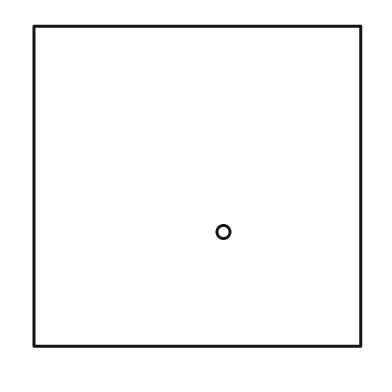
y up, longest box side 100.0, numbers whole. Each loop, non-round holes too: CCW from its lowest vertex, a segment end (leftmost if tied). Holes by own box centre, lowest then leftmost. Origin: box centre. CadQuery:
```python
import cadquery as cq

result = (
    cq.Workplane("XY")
    .moveTo(-50.0, -49.0)
    .lineTo(50.0, -49.0)
    .lineTo(50.0, 49.0)
    .lineTo(-50.0, 49.0)
    .close()
    .moveTo(8.0, -14.0)
    .circle(2.0)
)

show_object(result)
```